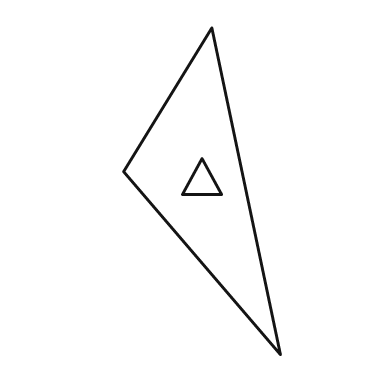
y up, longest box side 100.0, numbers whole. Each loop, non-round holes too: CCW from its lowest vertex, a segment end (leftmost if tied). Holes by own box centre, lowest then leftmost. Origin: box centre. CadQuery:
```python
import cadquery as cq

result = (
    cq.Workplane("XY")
    .moveTo(24.0, -50.0)
    .lineTo(3.0, 50.0)
    .lineTo(-24.0, 6.0)
    .close()
    .moveTo(-6.0, -1.0)
    .lineTo(6.0, -1.0)
    .lineTo(0.0, 10.0)
    .close()
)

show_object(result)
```